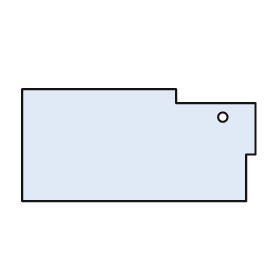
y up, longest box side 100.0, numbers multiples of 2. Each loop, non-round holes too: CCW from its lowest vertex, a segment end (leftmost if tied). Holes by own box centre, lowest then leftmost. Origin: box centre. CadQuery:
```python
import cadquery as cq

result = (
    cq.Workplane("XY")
    .moveTo(-50.0, -24.0)
    .lineTo(46.0, -24.0)
    .lineTo(46.0, -4.0)
    .lineTo(50.0, -4.0)
    .lineTo(50.0, 18.0)
    .lineTo(16.0, 18.0)
    .lineTo(16.0, 24.0)
    .lineTo(-50.0, 24.0)
    .close()
    .moveTo(36.0, 12.0)
    .circle(2.0)
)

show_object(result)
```